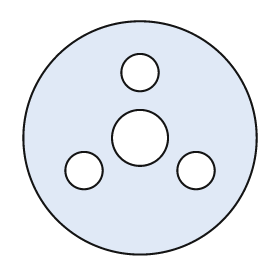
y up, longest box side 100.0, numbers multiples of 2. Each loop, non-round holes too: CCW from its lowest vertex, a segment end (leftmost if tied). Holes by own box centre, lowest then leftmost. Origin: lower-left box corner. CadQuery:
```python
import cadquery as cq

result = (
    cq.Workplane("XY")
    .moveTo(50.0, 50.0)
    .circle(50.0)
    .moveTo(26.0, 36.0)
    .circle(8.0)
    .moveTo(74.0, 36.0)
    .circle(8.0)
    .moveTo(50.0, 50.0)
    .circle(12.0)
    .moveTo(50.0, 78.0)
    .circle(8.0)
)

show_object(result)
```